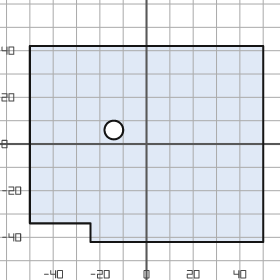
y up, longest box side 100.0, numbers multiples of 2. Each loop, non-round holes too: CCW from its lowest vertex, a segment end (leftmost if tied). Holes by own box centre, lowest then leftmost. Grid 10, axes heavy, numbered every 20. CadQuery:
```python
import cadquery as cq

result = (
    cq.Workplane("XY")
    .moveTo(-24.0, -42.0)
    .lineTo(50.0, -42.0)
    .lineTo(50.0, 42.0)
    .lineTo(-50.0, 42.0)
    .lineTo(-50.0, -34.0)
    .lineTo(-24.0, -34.0)
    .close()
    .moveTo(-14.0, 6.0)
    .circle(4.0)
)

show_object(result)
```